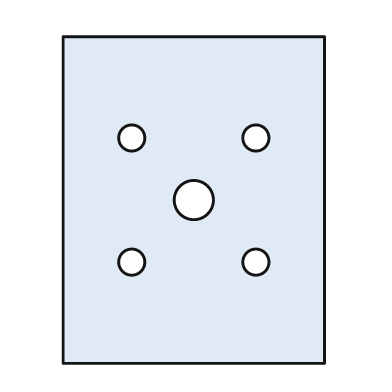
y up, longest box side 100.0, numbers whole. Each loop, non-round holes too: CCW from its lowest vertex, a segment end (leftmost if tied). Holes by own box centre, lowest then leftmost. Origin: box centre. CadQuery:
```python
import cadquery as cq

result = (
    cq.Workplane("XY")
    .moveTo(-40.0, -50.0)
    .lineTo(40.0, -50.0)
    .lineTo(40.0, 50.0)
    .lineTo(-40.0, 50.0)
    .close()
    .moveTo(-19.0, -19.0)
    .circle(4.0)
    .moveTo(19.0, -19.0)
    .circle(4.0)
    .moveTo(0.0, 0.0)
    .circle(6.0)
    .moveTo(-19.0, 19.0)
    .circle(4.0)
    .moveTo(19.0, 19.0)
    .circle(4.0)
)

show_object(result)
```